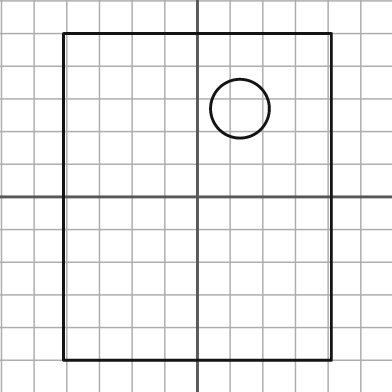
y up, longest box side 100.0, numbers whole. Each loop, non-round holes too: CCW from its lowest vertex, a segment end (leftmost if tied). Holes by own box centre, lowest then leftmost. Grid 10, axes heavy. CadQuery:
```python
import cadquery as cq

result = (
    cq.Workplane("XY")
    .moveTo(-41.0, -50.0)
    .lineTo(41.0, -50.0)
    .lineTo(41.0, 50.0)
    .lineTo(-41.0, 50.0)
    .close()
    .moveTo(13.0, 27.0)
    .circle(9.0)
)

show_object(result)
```